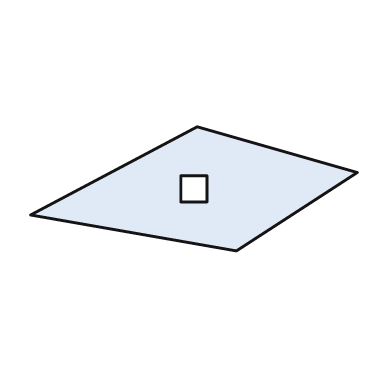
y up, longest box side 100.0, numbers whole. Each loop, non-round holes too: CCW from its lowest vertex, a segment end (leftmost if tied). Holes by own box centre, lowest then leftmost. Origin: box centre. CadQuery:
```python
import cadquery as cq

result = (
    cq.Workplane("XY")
    .moveTo(13.0, -19.0)
    .lineTo(50.0, 5.0)
    .lineTo(1.0, 19.0)
    .lineTo(-50.0, -8.0)
    .close()
    .moveTo(-4.0, -4.0)
    .lineTo(4.0, -4.0)
    .lineTo(4.0, 4.0)
    .lineTo(-4.0, 4.0)
    .close()
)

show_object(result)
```